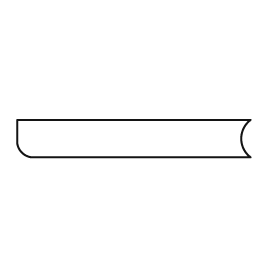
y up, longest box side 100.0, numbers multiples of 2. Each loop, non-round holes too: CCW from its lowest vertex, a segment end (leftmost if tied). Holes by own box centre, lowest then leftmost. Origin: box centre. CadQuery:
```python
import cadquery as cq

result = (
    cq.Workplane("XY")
    .moveTo(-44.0, -8.0)
    .lineTo(50.0, -8.0)
    .threePointArc((46.0, 0.0), (50.0, 8.0))
    .lineTo(-50.0, 8.0)
    .lineTo(-50.0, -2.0)
    .threePointArc((-48.0, -6.0), (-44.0, -8.0))
    .close()
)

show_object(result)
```